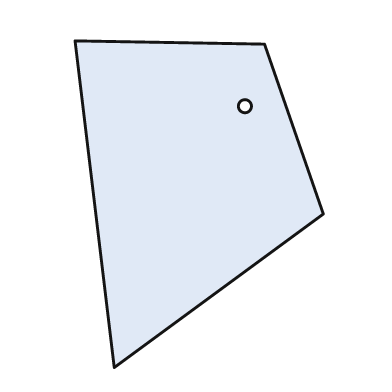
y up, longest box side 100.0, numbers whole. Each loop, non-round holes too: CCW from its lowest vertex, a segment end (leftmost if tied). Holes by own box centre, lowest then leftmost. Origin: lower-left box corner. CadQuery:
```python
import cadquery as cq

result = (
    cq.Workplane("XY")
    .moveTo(12.0, 0.0)
    .lineTo(76.0, 47.0)
    .lineTo(58.0, 99.0)
    .lineTo(0.0, 100.0)
    .close()
    .moveTo(52.0, 80.0)
    .circle(2.0)
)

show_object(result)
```